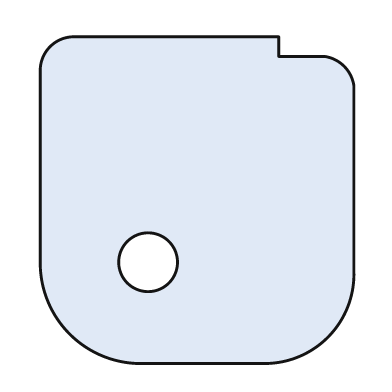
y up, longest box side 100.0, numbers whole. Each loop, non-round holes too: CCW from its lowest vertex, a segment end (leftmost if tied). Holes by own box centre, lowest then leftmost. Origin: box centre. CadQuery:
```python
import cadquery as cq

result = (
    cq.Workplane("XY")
    .moveTo(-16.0, -50.0)
    .lineTo(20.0, -50.0)
    .threePointArc((40.0, -42.0), (48.0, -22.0))
    .lineTo(48.0, 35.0)
    .threePointArc((45.0, 41.0), (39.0, 44.0))
    .lineTo(25.0, 44.0)
    .lineTo(25.0, 50.0)
    .lineTo(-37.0, 50.0)
    .threePointArc((-45.0, 47.0), (-48.0, 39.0))
    .lineTo(-48.0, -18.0)
    .threePointArc((-39.0, -41.0), (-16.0, -50.0))
    .close()
    .moveTo(-15.0, -19.0)
    .circle(9.0)
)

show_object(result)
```